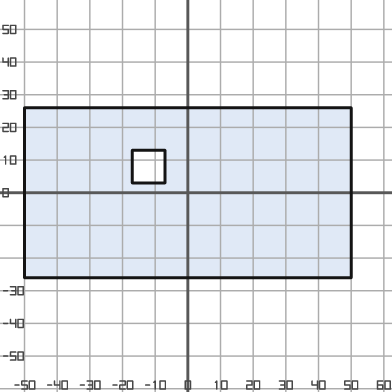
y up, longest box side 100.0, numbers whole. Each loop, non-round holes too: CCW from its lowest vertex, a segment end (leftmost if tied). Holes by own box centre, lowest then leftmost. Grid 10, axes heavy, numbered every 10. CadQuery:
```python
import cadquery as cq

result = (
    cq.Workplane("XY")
    .moveTo(-50.0, -26.0)
    .lineTo(50.0, -26.0)
    .lineTo(50.0, 26.0)
    .lineTo(-50.0, 26.0)
    .close()
    .moveTo(-17.0, 3.0)
    .lineTo(-7.0, 3.0)
    .lineTo(-7.0, 13.0)
    .lineTo(-17.0, 13.0)
    .close()
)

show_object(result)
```